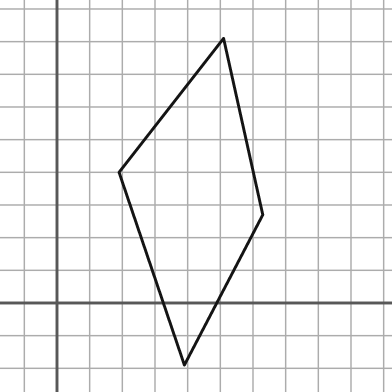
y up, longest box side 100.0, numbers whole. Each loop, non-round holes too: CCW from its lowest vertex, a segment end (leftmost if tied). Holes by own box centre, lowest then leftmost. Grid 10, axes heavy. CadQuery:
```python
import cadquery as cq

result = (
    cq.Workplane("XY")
    .moveTo(39.0, -19.0)
    .lineTo(63.0, 27.0)
    .lineTo(51.0, 81.0)
    .lineTo(19.0, 40.0)
    .close()
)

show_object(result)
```